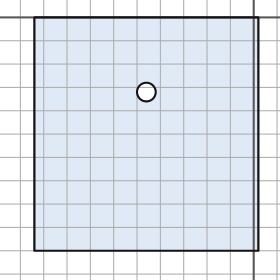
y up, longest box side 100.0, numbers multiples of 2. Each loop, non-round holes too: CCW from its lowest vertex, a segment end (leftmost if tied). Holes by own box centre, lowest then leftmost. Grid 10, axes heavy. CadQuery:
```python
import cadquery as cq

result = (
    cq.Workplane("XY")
    .moveTo(-94.0, -100.0)
    .lineTo(2.0, -100.0)
    .lineTo(2.0, 0.0)
    .lineTo(-94.0, 0.0)
    .close()
    .moveTo(-46.0, -32.0)
    .circle(4.0)
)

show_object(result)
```